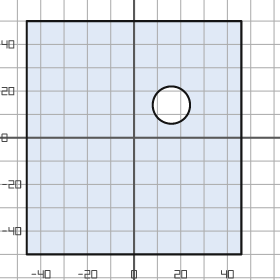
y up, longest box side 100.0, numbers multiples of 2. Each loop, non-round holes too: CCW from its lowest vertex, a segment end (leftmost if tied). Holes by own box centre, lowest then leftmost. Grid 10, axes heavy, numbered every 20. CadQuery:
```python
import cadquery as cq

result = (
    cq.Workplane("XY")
    .moveTo(-46.0, -50.0)
    .lineTo(46.0, -50.0)
    .lineTo(46.0, 50.0)
    .lineTo(-46.0, 50.0)
    .close()
    .moveTo(16.0, 14.0)
    .circle(8.0)
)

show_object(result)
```